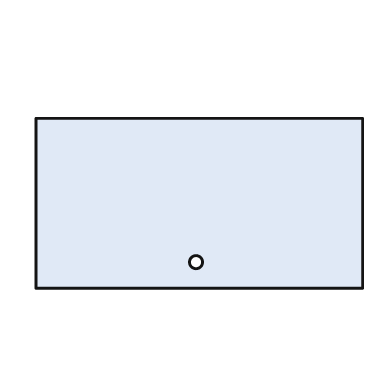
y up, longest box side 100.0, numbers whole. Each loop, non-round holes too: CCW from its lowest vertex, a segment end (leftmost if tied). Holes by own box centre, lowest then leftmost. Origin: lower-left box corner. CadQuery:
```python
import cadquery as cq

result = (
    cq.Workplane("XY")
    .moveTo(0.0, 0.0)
    .lineTo(100.0, 0.0)
    .lineTo(100.0, 52.0)
    .lineTo(0.0, 52.0)
    .close()
    .moveTo(49.0, 8.0)
    .circle(2.0)
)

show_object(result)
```